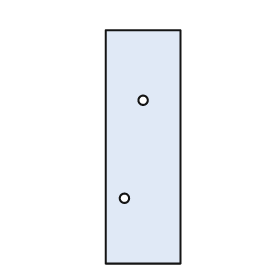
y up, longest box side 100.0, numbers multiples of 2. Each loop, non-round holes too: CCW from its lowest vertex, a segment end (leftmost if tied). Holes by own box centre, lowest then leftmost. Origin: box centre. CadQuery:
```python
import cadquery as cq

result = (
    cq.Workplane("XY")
    .moveTo(-16.0, -50.0)
    .lineTo(16.0, -50.0)
    .lineTo(16.0, 50.0)
    .lineTo(-16.0, 50.0)
    .close()
    .moveTo(-8.0, -22.0)
    .circle(2.0)
    .moveTo(0.0, 20.0)
    .circle(2.0)
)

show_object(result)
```